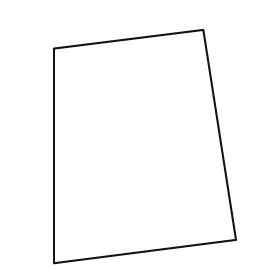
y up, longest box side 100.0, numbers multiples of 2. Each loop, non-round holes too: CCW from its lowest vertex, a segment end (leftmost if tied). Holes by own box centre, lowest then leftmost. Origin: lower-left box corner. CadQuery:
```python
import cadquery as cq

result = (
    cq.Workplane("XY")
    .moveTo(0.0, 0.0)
    .lineTo(78.0, 10.0)
    .lineTo(64.0, 100.0)
    .lineTo(0.0, 92.0)
    .close()
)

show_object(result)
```